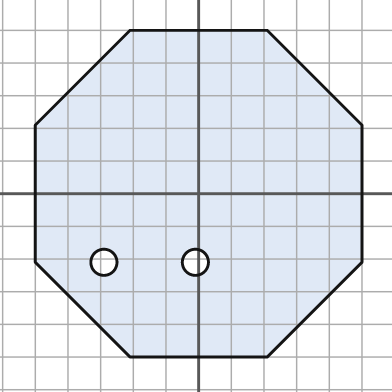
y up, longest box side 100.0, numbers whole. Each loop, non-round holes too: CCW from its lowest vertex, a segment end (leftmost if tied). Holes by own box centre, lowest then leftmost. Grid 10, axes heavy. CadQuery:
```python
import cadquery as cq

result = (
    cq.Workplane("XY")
    .moveTo(-21.0, -50.0)
    .lineTo(21.0, -50.0)
    .lineTo(50.0, -21.0)
    .lineTo(50.0, 21.0)
    .lineTo(21.0, 50.0)
    .lineTo(-21.0, 50.0)
    .lineTo(-50.0, 21.0)
    .lineTo(-50.0, -21.0)
    .close()
    .moveTo(-29.0, -21.0)
    .circle(4.0)
    .moveTo(-1.0, -21.0)
    .circle(4.0)
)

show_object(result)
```